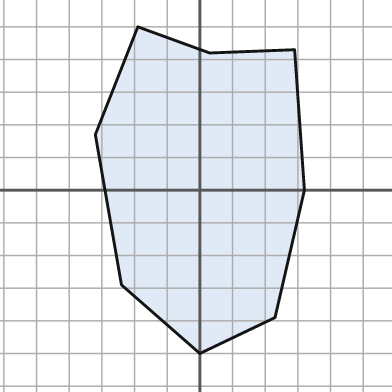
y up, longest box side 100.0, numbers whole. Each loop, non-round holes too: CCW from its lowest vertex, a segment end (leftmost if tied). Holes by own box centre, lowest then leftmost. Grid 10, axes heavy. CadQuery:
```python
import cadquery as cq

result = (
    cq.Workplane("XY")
    .moveTo(0.0, -50.0)
    .lineTo(23.0, -39.0)
    .lineTo(32.0, 0.0)
    .lineTo(29.0, 43.0)
    .lineTo(3.0, 42.0)
    .lineTo(-19.0, 50.0)
    .lineTo(-32.0, 17.0)
    .lineTo(-24.0, -29.0)
    .close()
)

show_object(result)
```